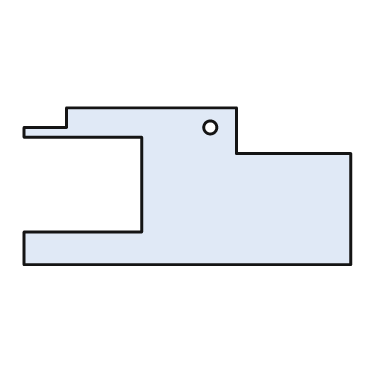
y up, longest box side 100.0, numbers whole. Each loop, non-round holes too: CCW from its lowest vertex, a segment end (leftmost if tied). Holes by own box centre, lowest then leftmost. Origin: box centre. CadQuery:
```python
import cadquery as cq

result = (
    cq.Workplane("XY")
    .moveTo(-50.0, -24.0)
    .lineTo(50.0, -24.0)
    .lineTo(50.0, 10.0)
    .lineTo(15.0, 10.0)
    .lineTo(15.0, 24.0)
    .lineTo(-37.0, 24.0)
    .lineTo(-37.0, 18.0)
    .lineTo(-50.0, 18.0)
    .lineTo(-50.0, 15.0)
    .lineTo(-14.0, 15.0)
    .lineTo(-14.0, -14.0)
    .lineTo(-50.0, -14.0)
    .close()
    .moveTo(7.0, 18.0)
    .circle(2.0)
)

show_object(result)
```